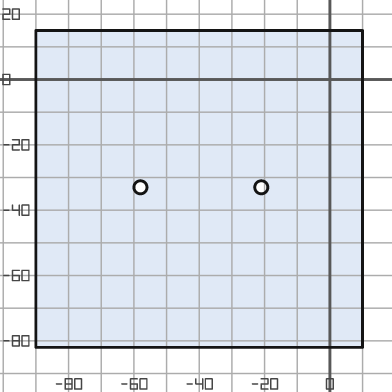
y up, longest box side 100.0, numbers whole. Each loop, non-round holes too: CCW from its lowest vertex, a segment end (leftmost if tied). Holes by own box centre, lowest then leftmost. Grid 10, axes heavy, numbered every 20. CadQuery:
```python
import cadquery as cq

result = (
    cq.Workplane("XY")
    .moveTo(-90.0, -82.0)
    .lineTo(10.0, -82.0)
    .lineTo(10.0, 15.0)
    .lineTo(-90.0, 15.0)
    .close()
    .moveTo(-58.0, -33.0)
    .circle(2.0)
    .moveTo(-21.0, -33.0)
    .circle(2.0)
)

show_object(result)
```